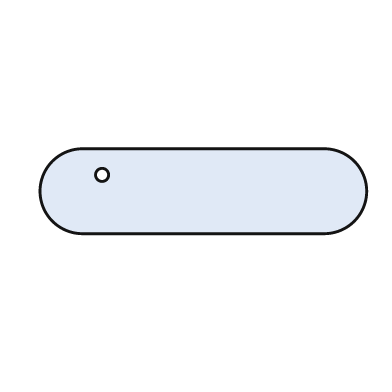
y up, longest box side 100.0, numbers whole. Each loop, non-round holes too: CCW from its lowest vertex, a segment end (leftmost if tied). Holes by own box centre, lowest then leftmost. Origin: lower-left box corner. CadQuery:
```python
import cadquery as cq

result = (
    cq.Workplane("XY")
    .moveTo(13.0, 0.0)
    .lineTo(87.0, 0.0)
    .threePointArc((100.0, 13.0), (87.0, 26.0))
    .lineTo(13.0, 26.0)
    .threePointArc((0.0, 13.0), (13.0, 0.0))
    .close()
    .moveTo(19.0, 18.0)
    .circle(2.0)
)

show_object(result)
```